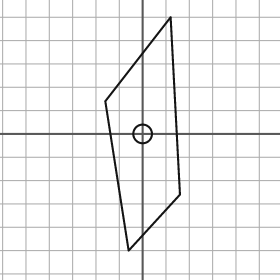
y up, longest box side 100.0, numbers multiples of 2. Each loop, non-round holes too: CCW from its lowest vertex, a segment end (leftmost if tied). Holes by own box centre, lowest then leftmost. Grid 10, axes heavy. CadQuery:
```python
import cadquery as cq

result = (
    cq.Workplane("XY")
    .moveTo(-6.0, -50.0)
    .lineTo(16.0, -26.0)
    .lineTo(12.0, 50.0)
    .lineTo(-16.0, 14.0)
    .close()
    .moveTo(0.0, 0.0)
    .circle(4.0)
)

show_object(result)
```